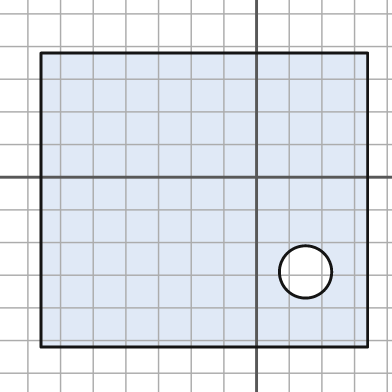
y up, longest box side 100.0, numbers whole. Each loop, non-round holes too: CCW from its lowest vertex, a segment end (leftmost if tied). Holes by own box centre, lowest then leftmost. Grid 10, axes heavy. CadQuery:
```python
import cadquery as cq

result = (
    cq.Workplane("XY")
    .moveTo(-66.0, -52.0)
    .lineTo(34.0, -52.0)
    .lineTo(34.0, 38.0)
    .lineTo(-66.0, 38.0)
    .close()
    .moveTo(15.0, -29.0)
    .circle(8.0)
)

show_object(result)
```